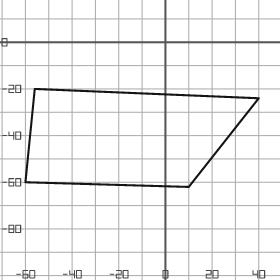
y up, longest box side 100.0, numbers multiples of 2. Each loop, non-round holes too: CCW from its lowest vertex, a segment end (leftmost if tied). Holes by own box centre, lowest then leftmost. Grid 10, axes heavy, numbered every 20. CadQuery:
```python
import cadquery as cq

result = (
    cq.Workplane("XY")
    .moveTo(10.0, -62.0)
    .lineTo(40.0, -24.0)
    .lineTo(-56.0, -20.0)
    .lineTo(-60.0, -60.0)
    .close()
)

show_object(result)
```